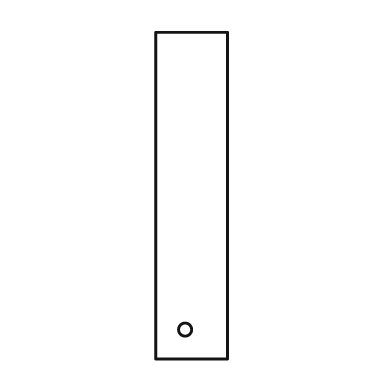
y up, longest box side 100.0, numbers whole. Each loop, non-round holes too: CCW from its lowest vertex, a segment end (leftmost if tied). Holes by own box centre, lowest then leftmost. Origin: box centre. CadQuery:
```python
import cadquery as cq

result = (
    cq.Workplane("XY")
    .moveTo(-11.0, -50.0)
    .lineTo(11.0, -50.0)
    .lineTo(11.0, 50.0)
    .lineTo(-11.0, 50.0)
    .close()
    .moveTo(-2.0, -41.0)
    .circle(2.0)
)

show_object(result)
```